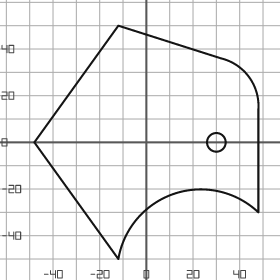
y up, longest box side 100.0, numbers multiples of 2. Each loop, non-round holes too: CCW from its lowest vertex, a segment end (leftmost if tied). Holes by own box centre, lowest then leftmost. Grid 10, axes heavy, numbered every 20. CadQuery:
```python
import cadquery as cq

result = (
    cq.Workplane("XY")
    .moveTo(-12.0, -50.0)
    .threePointArc((12.0, -22.0), (48.0, -30.0))
    .lineTo(48.0, 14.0)
    .threePointArc((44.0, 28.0), (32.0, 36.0))
    .lineTo(-12.0, 50.0)
    .lineTo(-48.0, 0.0)
    .close()
    .moveTo(30.0, 0.0)
    .circle(4.0)
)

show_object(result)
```